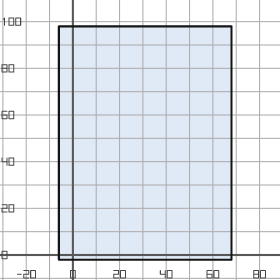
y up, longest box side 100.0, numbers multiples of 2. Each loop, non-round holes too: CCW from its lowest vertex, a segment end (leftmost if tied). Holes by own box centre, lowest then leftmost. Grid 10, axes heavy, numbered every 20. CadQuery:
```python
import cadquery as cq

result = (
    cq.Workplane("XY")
    .moveTo(-6.0, -2.0)
    .lineTo(68.0, -2.0)
    .lineTo(68.0, 98.0)
    .lineTo(-6.0, 98.0)
    .close()
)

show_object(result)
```